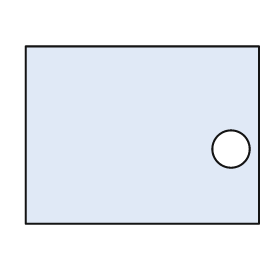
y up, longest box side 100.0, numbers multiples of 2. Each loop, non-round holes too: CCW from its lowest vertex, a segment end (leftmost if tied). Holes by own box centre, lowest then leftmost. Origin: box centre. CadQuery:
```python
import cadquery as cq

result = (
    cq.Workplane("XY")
    .moveTo(-50.0, -38.0)
    .lineTo(50.0, -38.0)
    .lineTo(50.0, 38.0)
    .lineTo(-50.0, 38.0)
    .close()
    .moveTo(38.0, -6.0)
    .circle(8.0)
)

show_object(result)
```